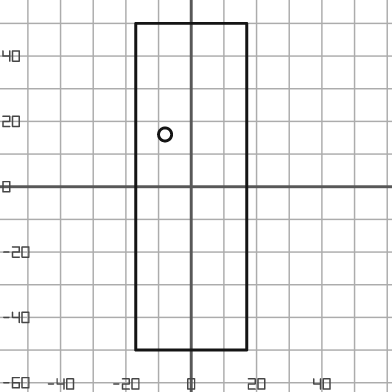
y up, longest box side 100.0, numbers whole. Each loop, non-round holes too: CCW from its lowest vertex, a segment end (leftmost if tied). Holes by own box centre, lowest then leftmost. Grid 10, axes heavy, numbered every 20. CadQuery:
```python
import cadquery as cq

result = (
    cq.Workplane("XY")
    .moveTo(-17.0, -50.0)
    .lineTo(17.0, -50.0)
    .lineTo(17.0, 50.0)
    .lineTo(-17.0, 50.0)
    .close()
    .moveTo(-8.0, 16.0)
    .circle(2.0)
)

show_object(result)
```